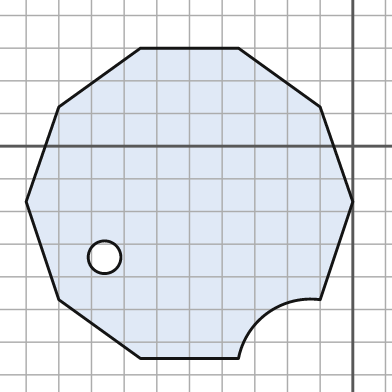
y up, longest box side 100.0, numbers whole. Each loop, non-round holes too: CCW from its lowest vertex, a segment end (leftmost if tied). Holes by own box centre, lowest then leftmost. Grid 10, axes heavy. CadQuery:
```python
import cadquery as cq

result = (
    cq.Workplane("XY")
    .moveTo(-65.0, -65.0)
    .lineTo(-35.0, -65.0)
    .threePointArc((-26.0, -51.0), (-10.0, -47.0))
    .lineTo(0.0, -17.0)
    .lineTo(-10.0, 12.0)
    .lineTo(-35.0, 30.0)
    .lineTo(-65.0, 30.0)
    .lineTo(-90.0, 12.0)
    .lineTo(-100.0, -17.0)
    .lineTo(-90.0, -47.0)
    .close()
    .moveTo(-76.0, -34.0)
    .circle(5.0)
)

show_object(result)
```